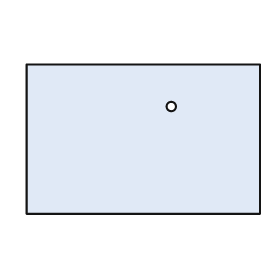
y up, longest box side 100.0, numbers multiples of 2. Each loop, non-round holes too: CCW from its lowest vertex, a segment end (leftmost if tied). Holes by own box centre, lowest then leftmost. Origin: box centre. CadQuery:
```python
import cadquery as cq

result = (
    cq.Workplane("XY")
    .moveTo(-50.0, -32.0)
    .lineTo(50.0, -32.0)
    .lineTo(50.0, 32.0)
    .lineTo(-50.0, 32.0)
    .close()
    .moveTo(12.0, 14.0)
    .circle(2.0)
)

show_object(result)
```